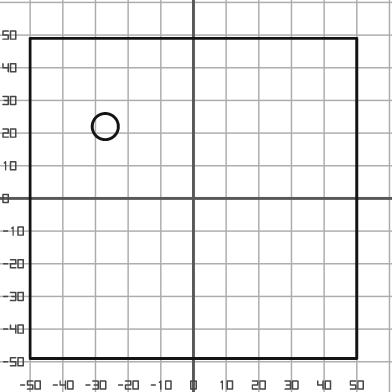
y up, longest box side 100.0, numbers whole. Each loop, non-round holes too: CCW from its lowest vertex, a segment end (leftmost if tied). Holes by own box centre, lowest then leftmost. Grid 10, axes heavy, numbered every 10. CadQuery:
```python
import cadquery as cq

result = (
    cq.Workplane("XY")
    .moveTo(-50.0, -49.0)
    .lineTo(50.0, -49.0)
    .lineTo(50.0, 49.0)
    .lineTo(-50.0, 49.0)
    .close()
    .moveTo(-27.0, 22.0)
    .circle(4.0)
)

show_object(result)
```